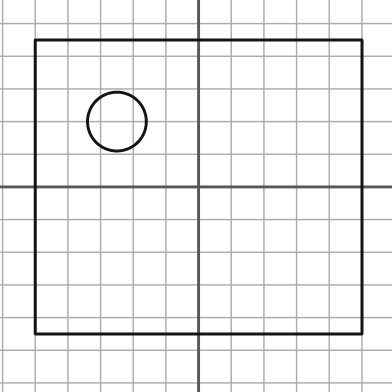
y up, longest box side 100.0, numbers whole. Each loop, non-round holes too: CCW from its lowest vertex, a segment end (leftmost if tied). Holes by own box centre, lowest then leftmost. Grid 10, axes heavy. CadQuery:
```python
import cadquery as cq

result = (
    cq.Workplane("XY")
    .moveTo(-50.0, -45.0)
    .lineTo(50.0, -45.0)
    .lineTo(50.0, 45.0)
    .lineTo(-50.0, 45.0)
    .close()
    .moveTo(-25.0, 20.0)
    .circle(9.0)
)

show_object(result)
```